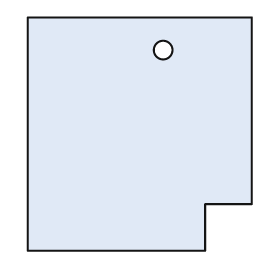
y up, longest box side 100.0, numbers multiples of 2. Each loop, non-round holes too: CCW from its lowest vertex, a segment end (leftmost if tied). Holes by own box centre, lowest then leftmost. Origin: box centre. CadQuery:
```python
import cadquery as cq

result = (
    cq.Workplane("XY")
    .moveTo(-48.0, -50.0)
    .lineTo(28.0, -50.0)
    .lineTo(28.0, -30.0)
    .lineTo(48.0, -30.0)
    .lineTo(48.0, 50.0)
    .lineTo(-48.0, 50.0)
    .close()
    .moveTo(10.0, 36.0)
    .circle(4.0)
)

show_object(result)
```